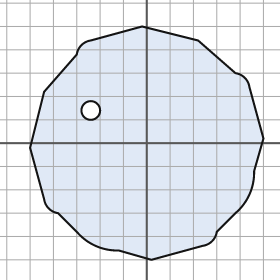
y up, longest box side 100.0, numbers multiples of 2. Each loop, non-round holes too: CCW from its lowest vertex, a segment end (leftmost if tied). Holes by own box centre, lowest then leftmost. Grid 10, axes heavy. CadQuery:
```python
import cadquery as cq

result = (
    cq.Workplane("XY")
    .moveTo(2.0, -50.0)
    .lineTo(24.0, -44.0)
    .threePointArc((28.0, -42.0), (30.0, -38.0))
    .lineTo(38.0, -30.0)
    .threePointArc((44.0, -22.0), (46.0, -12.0))
    .lineTo(50.0, 2.0)
    .lineTo(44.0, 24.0)
    .threePointArc((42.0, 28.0), (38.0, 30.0))
    .lineTo(22.0, 44.0)
    .lineTo(-2.0, 50.0)
    .lineTo(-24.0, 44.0)
    .threePointArc((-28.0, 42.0), (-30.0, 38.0))
    .lineTo(-44.0, 22.0)
    .lineTo(-50.0, -2.0)
    .lineTo(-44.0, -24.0)
    .threePointArc((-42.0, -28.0), (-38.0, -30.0))
    .lineTo(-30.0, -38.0)
    .threePointArc((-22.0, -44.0), (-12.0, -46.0))
    .close()
    .moveTo(-24.0, 14.0)
    .circle(4.0)
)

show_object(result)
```